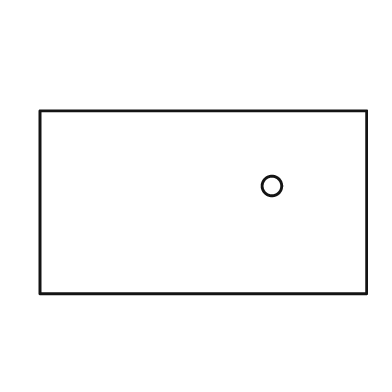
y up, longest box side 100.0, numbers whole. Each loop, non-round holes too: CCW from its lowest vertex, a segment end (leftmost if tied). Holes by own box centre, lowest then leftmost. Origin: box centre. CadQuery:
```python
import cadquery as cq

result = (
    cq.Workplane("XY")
    .moveTo(-50.0, -28.0)
    .lineTo(50.0, -28.0)
    .lineTo(50.0, 28.0)
    .lineTo(-50.0, 28.0)
    .close()
    .moveTo(21.0, 5.0)
    .circle(3.0)
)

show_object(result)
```